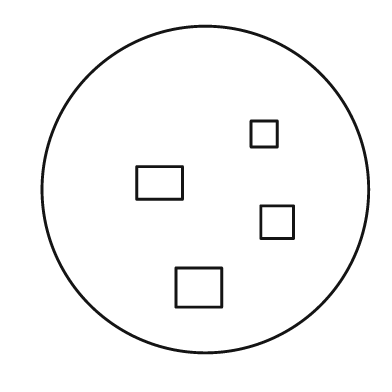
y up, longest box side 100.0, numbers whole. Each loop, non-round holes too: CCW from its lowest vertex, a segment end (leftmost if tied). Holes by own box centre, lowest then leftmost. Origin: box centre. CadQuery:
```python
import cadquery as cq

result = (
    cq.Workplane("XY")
    .moveTo(0.0, 0.0)
    .circle(50.0)
    .moveTo(-9.0, -36.0)
    .lineTo(5.0, -36.0)
    .lineTo(5.0, -24.0)
    .lineTo(-9.0, -24.0)
    .close()
    .moveTo(17.0, -15.0)
    .lineTo(27.0, -15.0)
    .lineTo(27.0, -5.0)
    .lineTo(17.0, -5.0)
    .close()
    .moveTo(-21.0, -3.0)
    .lineTo(-7.0, -3.0)
    .lineTo(-7.0, 7.0)
    .lineTo(-21.0, 7.0)
    .close()
    .moveTo(14.0, 13.0)
    .lineTo(22.0, 13.0)
    .lineTo(22.0, 21.0)
    .lineTo(14.0, 21.0)
    .close()
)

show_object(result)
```